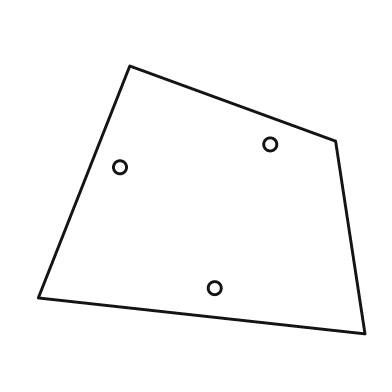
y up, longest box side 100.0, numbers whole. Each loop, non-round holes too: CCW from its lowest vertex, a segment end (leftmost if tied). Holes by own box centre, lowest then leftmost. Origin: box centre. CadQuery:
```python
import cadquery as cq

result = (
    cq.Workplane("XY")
    .moveTo(50.0, -41.0)
    .lineTo(41.0, 18.0)
    .lineTo(-22.0, 41.0)
    .lineTo(-50.0, -30.0)
    .close()
    .moveTo(4.0, -27.0)
    .circle(2.0)
    .moveTo(-25.0, 10.0)
    .circle(2.0)
    .moveTo(21.0, 17.0)
    .circle(2.0)
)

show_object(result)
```